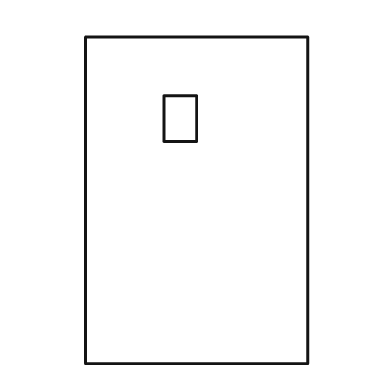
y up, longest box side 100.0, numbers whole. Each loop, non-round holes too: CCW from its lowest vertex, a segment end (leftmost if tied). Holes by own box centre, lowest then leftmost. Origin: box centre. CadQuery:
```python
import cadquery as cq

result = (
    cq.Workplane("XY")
    .moveTo(-34.0, -50.0)
    .lineTo(34.0, -50.0)
    .lineTo(34.0, 50.0)
    .lineTo(-34.0, 50.0)
    .close()
    .moveTo(-10.0, 18.0)
    .lineTo(0.0, 18.0)
    .lineTo(0.0, 32.0)
    .lineTo(-10.0, 32.0)
    .close()
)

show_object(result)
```